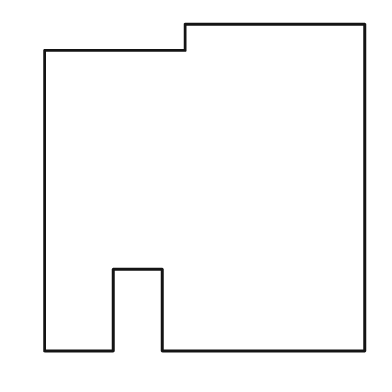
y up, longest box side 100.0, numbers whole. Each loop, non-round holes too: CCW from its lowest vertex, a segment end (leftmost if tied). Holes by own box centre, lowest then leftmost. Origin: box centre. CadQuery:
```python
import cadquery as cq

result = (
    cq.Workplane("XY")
    .moveTo(-49.0, -50.0)
    .lineTo(-28.0, -50.0)
    .lineTo(-28.0, -25.0)
    .lineTo(-13.0, -25.0)
    .lineTo(-13.0, -50.0)
    .lineTo(49.0, -50.0)
    .lineTo(49.0, 50.0)
    .lineTo(-6.0, 50.0)
    .lineTo(-6.0, 42.0)
    .lineTo(-49.0, 42.0)
    .close()
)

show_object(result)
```